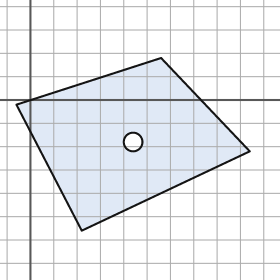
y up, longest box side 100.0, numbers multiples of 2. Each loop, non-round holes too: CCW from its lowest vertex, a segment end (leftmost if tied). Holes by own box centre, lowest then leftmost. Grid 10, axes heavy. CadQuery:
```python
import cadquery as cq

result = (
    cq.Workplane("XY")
    .moveTo(22.0, -56.0)
    .lineTo(94.0, -22.0)
    .lineTo(56.0, 18.0)
    .lineTo(-6.0, -2.0)
    .close()
    .moveTo(44.0, -18.0)
    .circle(4.0)
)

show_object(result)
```